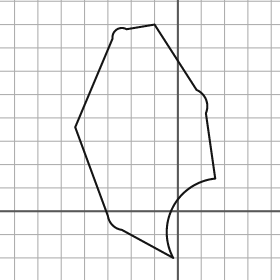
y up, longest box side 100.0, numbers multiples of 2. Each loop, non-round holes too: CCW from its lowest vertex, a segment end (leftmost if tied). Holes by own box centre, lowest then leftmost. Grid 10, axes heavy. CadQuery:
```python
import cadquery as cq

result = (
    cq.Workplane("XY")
    .moveTo(-2.0, -20.0)
    .threePointArc((-2.0, 2.0), (16.0, 14.0))
    .lineTo(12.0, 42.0)
    .threePointArc((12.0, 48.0), (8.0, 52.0))
    .lineTo(-10.0, 80.0)
    .lineTo(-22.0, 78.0)
    .threePointArc((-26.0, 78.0), (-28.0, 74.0))
    .lineTo(-44.0, 36.0)
    .lineTo(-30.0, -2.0)
    .threePointArc((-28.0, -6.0), (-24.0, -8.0))
    .close()
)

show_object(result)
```